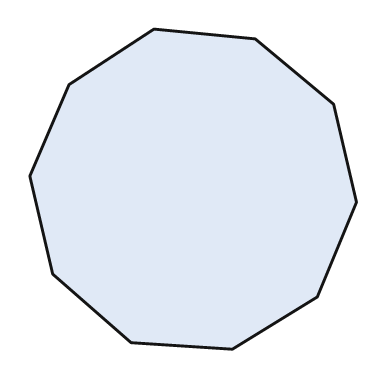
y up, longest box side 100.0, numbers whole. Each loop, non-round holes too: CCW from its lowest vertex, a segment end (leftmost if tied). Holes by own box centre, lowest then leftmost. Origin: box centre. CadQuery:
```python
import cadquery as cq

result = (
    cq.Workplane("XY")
    .moveTo(12.0, -49.0)
    .lineTo(38.0, -33.0)
    .lineTo(50.0, -4.0)
    .lineTo(43.0, 26.0)
    .lineTo(19.0, 46.0)
    .lineTo(-12.0, 49.0)
    .lineTo(-38.0, 32.0)
    .lineTo(-50.0, 4.0)
    .lineTo(-43.0, -26.0)
    .lineTo(-19.0, -47.0)
    .close()
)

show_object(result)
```